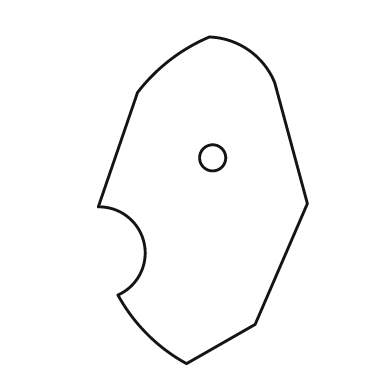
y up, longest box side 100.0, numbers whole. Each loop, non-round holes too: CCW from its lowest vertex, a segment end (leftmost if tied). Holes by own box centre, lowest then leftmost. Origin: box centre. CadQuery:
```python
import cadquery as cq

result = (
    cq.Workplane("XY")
    .moveTo(-5.0, -50.0)
    .lineTo(16.0, -38.0)
    .lineTo(32.0, -1.0)
    .lineTo(22.0, 36.0)
    .threePointArc((14.0, 46.0), (2.0, 50.0))
    .threePointArc((-10.0, 43.0), (-20.0, 33.0))
    .lineTo(-32.0, -2.0)
    .threePointArc((-18.0, -13.0), (-26.0, -29.0))
    .threePointArc((-17.0, -41.0), (-5.0, -50.0))
    .close()
    .moveTo(3.0, 13.0)
    .circle(4.0)
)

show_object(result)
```